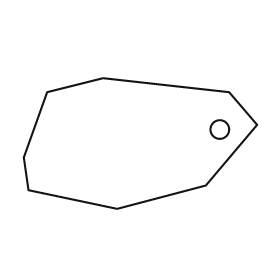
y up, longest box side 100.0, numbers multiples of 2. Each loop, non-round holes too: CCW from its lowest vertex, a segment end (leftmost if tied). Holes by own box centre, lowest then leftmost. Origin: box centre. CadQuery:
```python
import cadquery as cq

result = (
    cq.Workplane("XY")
    .moveTo(-10.0, -28.0)
    .lineTo(28.0, -18.0)
    .lineTo(50.0, 8.0)
    .lineTo(38.0, 22.0)
    .lineTo(-16.0, 28.0)
    .lineTo(-40.0, 22.0)
    .lineTo(-50.0, -6.0)
    .lineTo(-48.0, -20.0)
    .close()
    .moveTo(34.0, 6.0)
    .circle(4.0)
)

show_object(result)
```